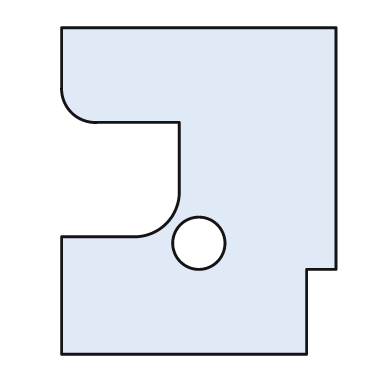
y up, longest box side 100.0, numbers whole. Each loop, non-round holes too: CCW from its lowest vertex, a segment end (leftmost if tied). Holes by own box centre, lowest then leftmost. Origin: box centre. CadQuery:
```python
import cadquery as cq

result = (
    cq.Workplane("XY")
    .moveTo(-42.0, -50.0)
    .lineTo(33.0, -50.0)
    .lineTo(33.0, -24.0)
    .lineTo(42.0, -24.0)
    .lineTo(42.0, 50.0)
    .lineTo(-42.0, 50.0)
    .lineTo(-42.0, 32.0)
    .threePointArc((-39.0, 24.0), (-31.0, 21.0))
    .lineTo(-6.0, 21.0)
    .lineTo(-6.0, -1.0)
    .threePointArc((-10.0, -10.0), (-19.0, -14.0))
    .lineTo(-42.0, -14.0)
    .close()
    .moveTo(0.0, -16.0)
    .circle(8.0)
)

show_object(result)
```